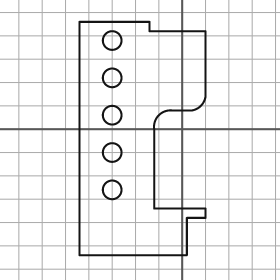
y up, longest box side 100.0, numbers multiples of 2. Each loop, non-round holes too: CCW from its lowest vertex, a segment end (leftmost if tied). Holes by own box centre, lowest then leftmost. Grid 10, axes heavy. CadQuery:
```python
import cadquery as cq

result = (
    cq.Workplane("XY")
    .moveTo(-44.0, -54.0)
    .lineTo(2.0, -54.0)
    .lineTo(2.0, -38.0)
    .lineTo(10.0, -38.0)
    .lineTo(10.0, -34.0)
    .lineTo(-12.0, -34.0)
    .lineTo(-12.0, 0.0)
    .threePointArc((-10.0, 6.0), (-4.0, 8.0))
    .lineTo(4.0, 8.0)
    .threePointArc((8.0, 10.0), (10.0, 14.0))
    .lineTo(10.0, 42.0)
    .lineTo(-14.0, 42.0)
    .lineTo(-14.0, 46.0)
    .lineTo(-44.0, 46.0)
    .close()
    .moveTo(-30.0, -26.0)
    .circle(4.0)
    .moveTo(-30.0, -10.0)
    .circle(4.0)
    .moveTo(-30.0, 6.0)
    .circle(4.0)
    .moveTo(-30.0, 22.0)
    .circle(4.0)
    .moveTo(-30.0, 38.0)
    .circle(4.0)
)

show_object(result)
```